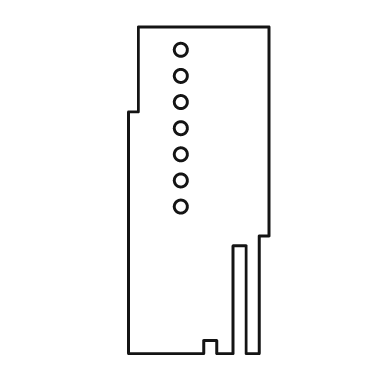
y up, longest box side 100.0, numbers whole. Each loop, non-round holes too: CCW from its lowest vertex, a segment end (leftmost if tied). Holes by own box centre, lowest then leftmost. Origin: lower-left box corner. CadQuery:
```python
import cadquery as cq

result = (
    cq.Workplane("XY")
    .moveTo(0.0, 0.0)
    .lineTo(23.0, 0.0)
    .lineTo(23.0, 4.0)
    .lineTo(27.0, 4.0)
    .lineTo(27.0, 0.0)
    .lineTo(32.0, 0.0)
    .lineTo(32.0, 33.0)
    .lineTo(36.0, 33.0)
    .lineTo(36.0, 0.0)
    .lineTo(40.0, 0.0)
    .lineTo(40.0, 36.0)
    .lineTo(43.0, 36.0)
    .lineTo(43.0, 100.0)
    .lineTo(3.0, 100.0)
    .lineTo(3.0, 74.0)
    .lineTo(0.0, 74.0)
    .close()
    .moveTo(16.0, 45.0)
    .circle(2.0)
    .moveTo(16.0, 53.0)
    .circle(2.0)
    .moveTo(16.0, 61.0)
    .circle(2.0)
    .moveTo(16.0, 69.0)
    .circle(2.0)
    .moveTo(16.0, 77.0)
    .circle(2.0)
    .moveTo(16.0, 85.0)
    .circle(2.0)
    .moveTo(16.0, 93.0)
    .circle(2.0)
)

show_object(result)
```